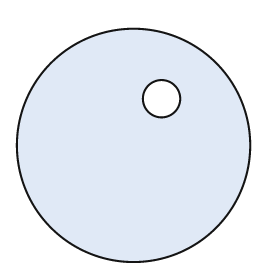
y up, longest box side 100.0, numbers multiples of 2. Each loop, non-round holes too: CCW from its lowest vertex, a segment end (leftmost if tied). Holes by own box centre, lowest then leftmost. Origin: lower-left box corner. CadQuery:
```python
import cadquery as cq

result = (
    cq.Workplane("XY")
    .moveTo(50.0, 50.0)
    .circle(50.0)
    .moveTo(62.0, 70.0)
    .circle(8.0)
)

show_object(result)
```